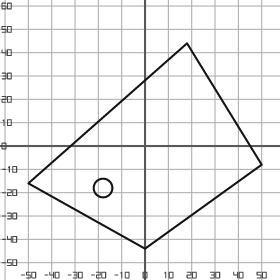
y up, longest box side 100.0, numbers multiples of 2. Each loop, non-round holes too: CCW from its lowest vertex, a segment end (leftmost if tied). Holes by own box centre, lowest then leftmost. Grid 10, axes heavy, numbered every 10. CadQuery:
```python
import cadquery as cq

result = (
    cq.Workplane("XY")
    .moveTo(0.0, -44.0)
    .lineTo(50.0, -8.0)
    .lineTo(18.0, 44.0)
    .lineTo(-50.0, -16.0)
    .close()
    .moveTo(-18.0, -18.0)
    .circle(4.0)
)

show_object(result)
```